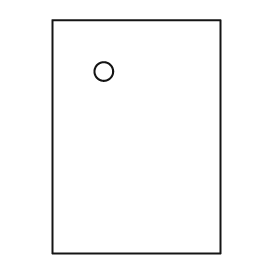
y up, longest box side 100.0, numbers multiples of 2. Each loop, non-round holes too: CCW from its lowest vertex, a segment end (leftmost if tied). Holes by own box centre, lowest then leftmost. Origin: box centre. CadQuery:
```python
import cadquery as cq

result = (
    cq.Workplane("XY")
    .moveTo(-36.0, -50.0)
    .lineTo(36.0, -50.0)
    .lineTo(36.0, 50.0)
    .lineTo(-36.0, 50.0)
    .close()
    .moveTo(-14.0, 28.0)
    .circle(4.0)
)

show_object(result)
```